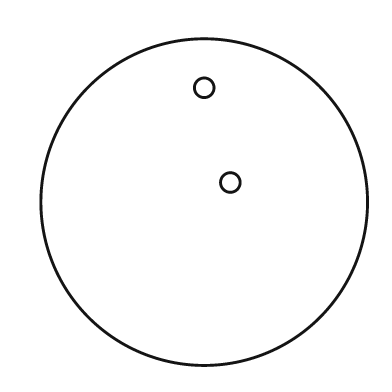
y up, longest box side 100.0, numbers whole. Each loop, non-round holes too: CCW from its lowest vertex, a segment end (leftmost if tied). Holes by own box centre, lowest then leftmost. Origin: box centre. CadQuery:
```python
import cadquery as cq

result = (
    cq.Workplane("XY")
    .moveTo(0.0, 0.0)
    .circle(50.0)
    .moveTo(8.0, 6.0)
    .circle(3.0)
    .moveTo(0.0, 35.0)
    .circle(3.0)
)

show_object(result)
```